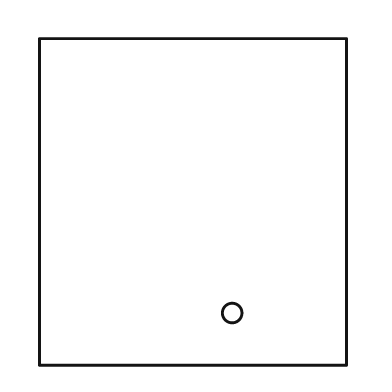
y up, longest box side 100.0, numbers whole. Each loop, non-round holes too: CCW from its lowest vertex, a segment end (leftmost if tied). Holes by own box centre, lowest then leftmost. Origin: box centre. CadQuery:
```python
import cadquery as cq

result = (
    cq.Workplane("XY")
    .moveTo(-47.0, -50.0)
    .lineTo(47.0, -50.0)
    .lineTo(47.0, 50.0)
    .lineTo(-47.0, 50.0)
    .close()
    .moveTo(12.0, -34.0)
    .circle(3.0)
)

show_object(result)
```